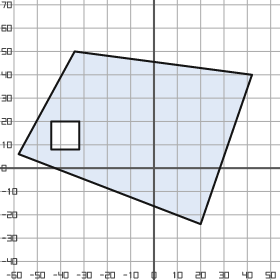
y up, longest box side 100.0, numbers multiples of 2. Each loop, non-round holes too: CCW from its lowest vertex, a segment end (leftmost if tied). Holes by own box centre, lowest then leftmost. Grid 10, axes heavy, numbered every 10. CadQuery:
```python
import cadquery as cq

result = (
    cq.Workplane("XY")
    .moveTo(20.0, -24.0)
    .lineTo(42.0, 40.0)
    .lineTo(-34.0, 50.0)
    .lineTo(-58.0, 6.0)
    .close()
    .moveTo(-44.0, 8.0)
    .lineTo(-32.0, 8.0)
    .lineTo(-32.0, 20.0)
    .lineTo(-44.0, 20.0)
    .close()
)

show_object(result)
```